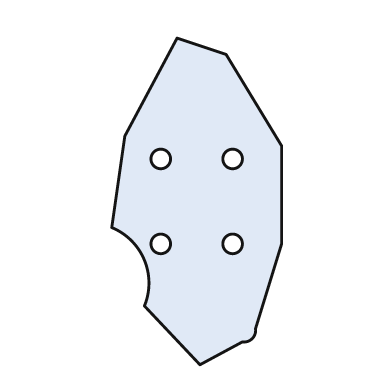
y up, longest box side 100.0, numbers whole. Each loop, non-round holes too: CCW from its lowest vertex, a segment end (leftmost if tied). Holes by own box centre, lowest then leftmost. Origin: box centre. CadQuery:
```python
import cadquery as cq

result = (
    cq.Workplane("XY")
    .moveTo(1.0, -50.0)
    .lineTo(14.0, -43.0)
    .threePointArc((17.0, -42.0), (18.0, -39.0))
    .lineTo(26.0, -13.0)
    .lineTo(26.0, 17.0)
    .lineTo(9.0, 45.0)
    .lineTo(-6.0, 50.0)
    .lineTo(-22.0, 20.0)
    .lineTo(-26.0, -8.0)
    .threePointArc((-16.0, -18.0), (-16.0, -32.0))
    .close()
    .moveTo(-11.0, -13.0)
    .circle(3.0)
    .moveTo(11.0, -13.0)
    .circle(3.0)
    .moveTo(-11.0, 13.0)
    .circle(3.0)
    .moveTo(11.0, 13.0)
    .circle(3.0)
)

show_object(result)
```